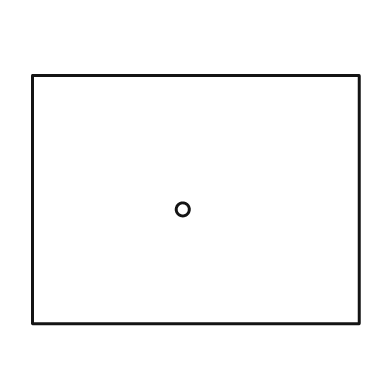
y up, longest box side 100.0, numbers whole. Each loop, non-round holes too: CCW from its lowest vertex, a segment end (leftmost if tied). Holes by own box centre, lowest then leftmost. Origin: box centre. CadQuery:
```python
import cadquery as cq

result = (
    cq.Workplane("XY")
    .moveTo(-50.0, -38.0)
    .lineTo(50.0, -38.0)
    .lineTo(50.0, 38.0)
    .lineTo(-50.0, 38.0)
    .close()
    .moveTo(-4.0, -3.0)
    .circle(2.0)
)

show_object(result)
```